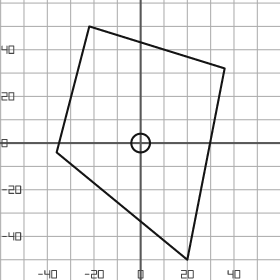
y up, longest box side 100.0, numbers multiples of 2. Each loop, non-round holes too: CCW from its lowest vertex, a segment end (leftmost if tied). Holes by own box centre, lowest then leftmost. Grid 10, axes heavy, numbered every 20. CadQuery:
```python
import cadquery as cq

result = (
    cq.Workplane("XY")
    .moveTo(20.0, -50.0)
    .lineTo(36.0, 32.0)
    .lineTo(-22.0, 50.0)
    .lineTo(-36.0, -4.0)
    .close()
    .moveTo(0.0, 0.0)
    .circle(4.0)
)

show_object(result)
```